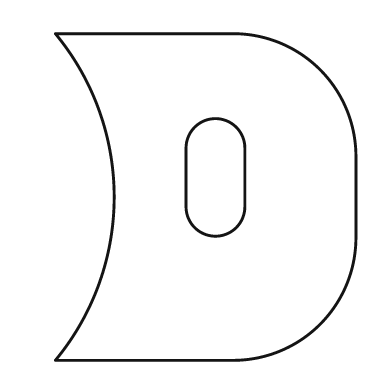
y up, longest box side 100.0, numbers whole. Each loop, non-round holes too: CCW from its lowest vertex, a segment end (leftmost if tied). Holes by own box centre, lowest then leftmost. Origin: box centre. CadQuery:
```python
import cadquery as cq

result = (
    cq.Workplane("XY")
    .moveTo(-46.0, -50.0)
    .lineTo(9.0, -50.0)
    .threePointArc((35.0, -39.0), (46.0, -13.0))
    .lineTo(46.0, 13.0)
    .threePointArc((35.0, 39.0), (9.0, 50.0))
    .lineTo(-46.0, 50.0)
    .threePointArc((-28.0, 0.0), (-46.0, -50.0))
    .close()
    .moveTo(-6.0, -3.0)
    .threePointArc((3.0, -12.0), (12.0, -3.0))
    .lineTo(12.0, 15.0)
    .threePointArc((3.0, 24.0), (-6.0, 15.0))
    .close()
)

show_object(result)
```